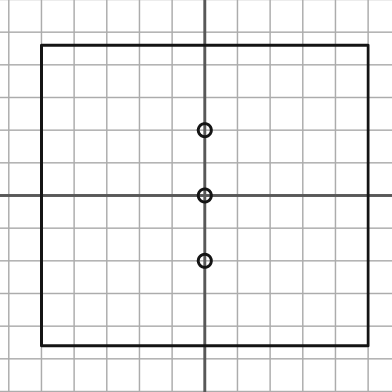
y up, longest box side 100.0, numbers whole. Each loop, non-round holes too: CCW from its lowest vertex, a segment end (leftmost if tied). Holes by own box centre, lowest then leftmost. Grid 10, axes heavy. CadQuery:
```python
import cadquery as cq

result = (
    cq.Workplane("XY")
    .moveTo(-50.0, -46.0)
    .lineTo(50.0, -46.0)
    .lineTo(50.0, 46.0)
    .lineTo(-50.0, 46.0)
    .close()
    .moveTo(0.0, -20.0)
    .circle(2.0)
    .moveTo(0.0, 0.0)
    .circle(2.0)
    .moveTo(0.0, 20.0)
    .circle(2.0)
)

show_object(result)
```